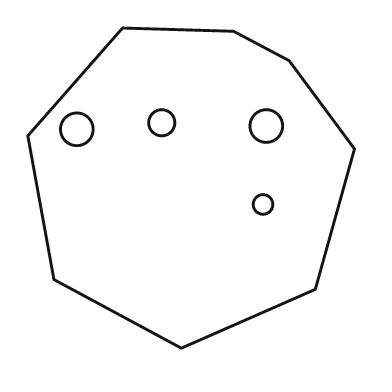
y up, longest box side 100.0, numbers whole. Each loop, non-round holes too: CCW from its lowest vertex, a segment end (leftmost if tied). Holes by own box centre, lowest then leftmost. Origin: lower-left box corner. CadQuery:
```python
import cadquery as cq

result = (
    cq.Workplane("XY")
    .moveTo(47.0, 0.0)
    .lineTo(88.0, 18.0)
    .lineTo(100.0, 61.0)
    .lineTo(80.0, 88.0)
    .lineTo(63.0, 97.0)
    .lineTo(29.0, 98.0)
    .lineTo(0.0, 65.0)
    .lineTo(8.0, 21.0)
    .close()
    .moveTo(72.0, 44.0)
    .circle(3.0)
    .moveTo(15.0, 67.0)
    .circle(5.0)
    .moveTo(73.0, 68.0)
    .circle(5.0)
    .moveTo(41.0, 69.0)
    .circle(4.0)
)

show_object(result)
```